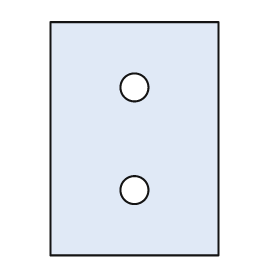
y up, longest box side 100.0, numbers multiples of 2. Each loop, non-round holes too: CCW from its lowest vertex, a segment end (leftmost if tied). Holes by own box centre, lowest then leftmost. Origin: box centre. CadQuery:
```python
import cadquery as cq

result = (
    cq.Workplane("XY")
    .moveTo(-36.0, -50.0)
    .lineTo(36.0, -50.0)
    .lineTo(36.0, 50.0)
    .lineTo(-36.0, 50.0)
    .close()
    .moveTo(0.0, -22.0)
    .circle(6.0)
    .moveTo(0.0, 22.0)
    .circle(6.0)
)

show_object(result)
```